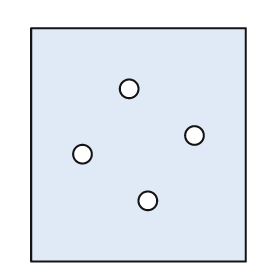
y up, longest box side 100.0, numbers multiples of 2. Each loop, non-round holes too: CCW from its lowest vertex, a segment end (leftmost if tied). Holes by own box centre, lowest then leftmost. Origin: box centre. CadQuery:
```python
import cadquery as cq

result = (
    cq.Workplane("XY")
    .moveTo(-46.0, -50.0)
    .lineTo(46.0, -50.0)
    .lineTo(46.0, 50.0)
    .lineTo(-46.0, 50.0)
    .close()
    .moveTo(4.0, -24.0)
    .circle(4.0)
    .moveTo(-24.0, -4.0)
    .circle(4.0)
    .moveTo(24.0, 4.0)
    .circle(4.0)
    .moveTo(-4.0, 24.0)
    .circle(4.0)
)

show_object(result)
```